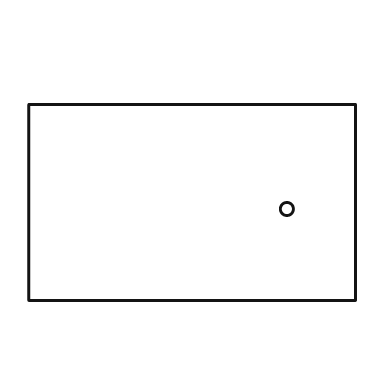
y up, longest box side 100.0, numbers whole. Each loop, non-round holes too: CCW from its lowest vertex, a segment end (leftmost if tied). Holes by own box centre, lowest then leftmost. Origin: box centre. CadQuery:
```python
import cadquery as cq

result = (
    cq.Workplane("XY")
    .moveTo(-50.0, -30.0)
    .lineTo(50.0, -30.0)
    .lineTo(50.0, 30.0)
    .lineTo(-50.0, 30.0)
    .close()
    .moveTo(29.0, -2.0)
    .circle(2.0)
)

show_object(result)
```